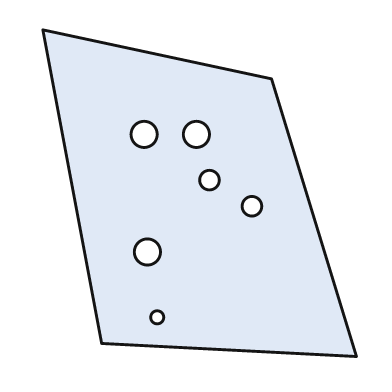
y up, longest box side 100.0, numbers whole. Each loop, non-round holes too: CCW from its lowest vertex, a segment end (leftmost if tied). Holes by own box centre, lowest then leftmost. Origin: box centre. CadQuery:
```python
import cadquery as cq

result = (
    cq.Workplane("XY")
    .moveTo(48.0, -50.0)
    .lineTo(22.0, 35.0)
    .lineTo(-48.0, 50.0)
    .lineTo(-30.0, -46.0)
    .close()
    .moveTo(-13.0, -38.0)
    .circle(2.0)
    .moveTo(-16.0, -18.0)
    .circle(4.0)
    .moveTo(16.0, -4.0)
    .circle(3.0)
    .moveTo(3.0, 4.0)
    .circle(3.0)
    .moveTo(-17.0, 18.0)
    .circle(4.0)
    .moveTo(-1.0, 18.0)
    .circle(4.0)
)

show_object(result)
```